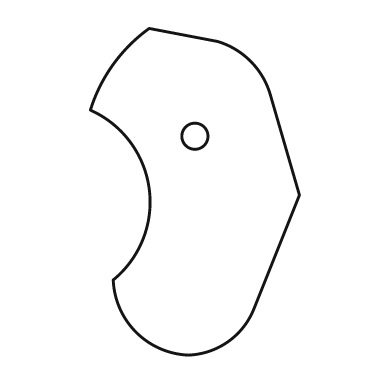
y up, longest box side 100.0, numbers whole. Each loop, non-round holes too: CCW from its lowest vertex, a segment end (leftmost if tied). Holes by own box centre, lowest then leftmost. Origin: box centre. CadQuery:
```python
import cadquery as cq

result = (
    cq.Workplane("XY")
    .moveTo(-2.0, -50.0)
    .threePointArc((10.0, -46.0), (18.0, -36.0))
    .lineTo(32.0, -1.0)
    .lineTo(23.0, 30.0)
    .threePointArc((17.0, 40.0), (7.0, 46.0))
    .lineTo(-14.0, 50.0)
    .threePointArc((-25.0, 39.0), (-32.0, 25.0))
    .threePointArc((-14.0, 1.0), (-25.0, -27.0))
    .threePointArc((-18.0, -43.0), (-2.0, -50.0))
    .close()
    .moveTo(0.0, 17.0)
    .circle(4.0)
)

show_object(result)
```